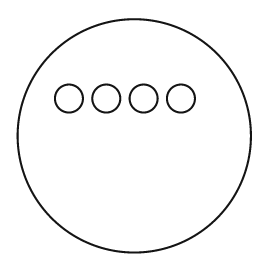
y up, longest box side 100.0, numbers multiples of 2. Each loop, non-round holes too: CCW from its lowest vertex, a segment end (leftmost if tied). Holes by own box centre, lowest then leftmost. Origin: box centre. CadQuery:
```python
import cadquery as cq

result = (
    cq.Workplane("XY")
    .moveTo(0.0, 0.0)
    .circle(50.0)
    .moveTo(-28.0, 16.0)
    .circle(6.0)
    .moveTo(-12.0, 16.0)
    .circle(6.0)
    .moveTo(4.0, 16.0)
    .circle(6.0)
    .moveTo(20.0, 16.0)
    .circle(6.0)
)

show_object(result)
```